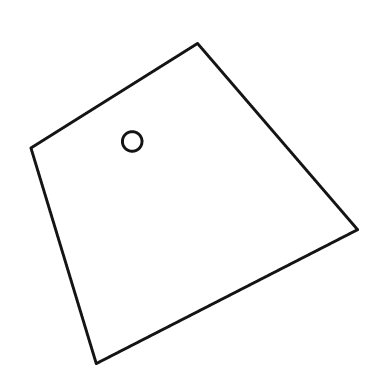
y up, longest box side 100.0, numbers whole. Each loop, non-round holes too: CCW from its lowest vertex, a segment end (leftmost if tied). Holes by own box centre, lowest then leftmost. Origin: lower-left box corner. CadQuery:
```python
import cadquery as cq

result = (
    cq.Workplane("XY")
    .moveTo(20.0, 0.0)
    .lineTo(100.0, 41.0)
    .lineTo(51.0, 98.0)
    .lineTo(0.0, 66.0)
    .close()
    .moveTo(31.0, 68.0)
    .circle(3.0)
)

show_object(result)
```